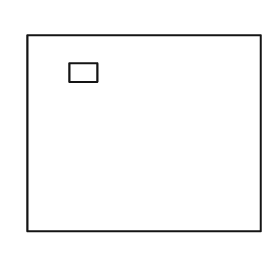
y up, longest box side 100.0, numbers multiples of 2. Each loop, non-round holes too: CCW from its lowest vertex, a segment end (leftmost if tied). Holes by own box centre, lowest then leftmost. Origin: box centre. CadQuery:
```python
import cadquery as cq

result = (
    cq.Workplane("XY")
    .moveTo(-50.0, -42.0)
    .lineTo(50.0, -42.0)
    .lineTo(50.0, 42.0)
    .lineTo(-50.0, 42.0)
    .close()
    .moveTo(-32.0, 22.0)
    .lineTo(-20.0, 22.0)
    .lineTo(-20.0, 30.0)
    .lineTo(-32.0, 30.0)
    .close()
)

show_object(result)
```